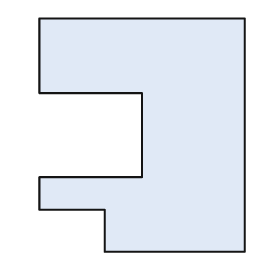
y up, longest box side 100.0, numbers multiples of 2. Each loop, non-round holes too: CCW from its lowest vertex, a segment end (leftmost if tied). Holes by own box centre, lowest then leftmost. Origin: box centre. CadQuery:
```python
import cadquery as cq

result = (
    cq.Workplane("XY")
    .moveTo(-16.0, -50.0)
    .lineTo(44.0, -50.0)
    .lineTo(44.0, 50.0)
    .lineTo(-44.0, 50.0)
    .lineTo(-44.0, 18.0)
    .lineTo(0.0, 18.0)
    .lineTo(0.0, -18.0)
    .lineTo(-44.0, -18.0)
    .lineTo(-44.0, -32.0)
    .lineTo(-16.0, -32.0)
    .close()
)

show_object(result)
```